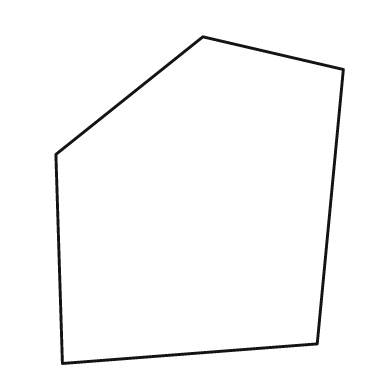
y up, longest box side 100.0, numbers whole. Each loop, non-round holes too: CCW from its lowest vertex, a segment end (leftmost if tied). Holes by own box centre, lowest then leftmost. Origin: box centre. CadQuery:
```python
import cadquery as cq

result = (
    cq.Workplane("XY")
    .moveTo(-42.0, -50.0)
    .lineTo(36.0, -44.0)
    .lineTo(44.0, 40.0)
    .lineTo(1.0, 50.0)
    .lineTo(-44.0, 14.0)
    .close()
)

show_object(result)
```